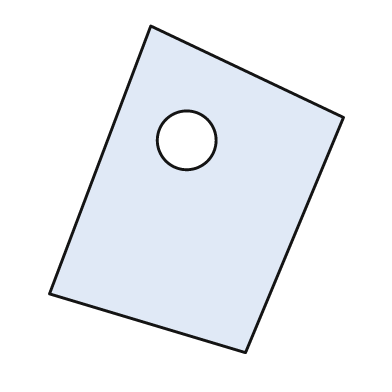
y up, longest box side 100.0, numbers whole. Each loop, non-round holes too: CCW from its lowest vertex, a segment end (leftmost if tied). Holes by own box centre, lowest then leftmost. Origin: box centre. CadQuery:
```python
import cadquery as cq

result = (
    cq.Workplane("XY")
    .moveTo(15.0, -50.0)
    .lineTo(45.0, 22.0)
    .lineTo(-14.0, 50.0)
    .lineTo(-45.0, -32.0)
    .close()
    .moveTo(-3.0, 15.0)
    .circle(9.0)
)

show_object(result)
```